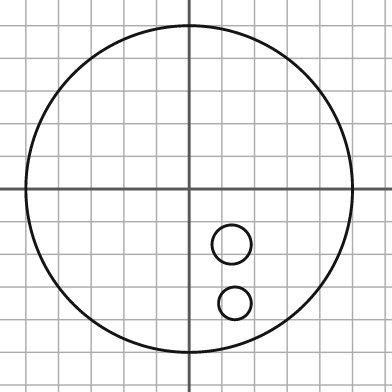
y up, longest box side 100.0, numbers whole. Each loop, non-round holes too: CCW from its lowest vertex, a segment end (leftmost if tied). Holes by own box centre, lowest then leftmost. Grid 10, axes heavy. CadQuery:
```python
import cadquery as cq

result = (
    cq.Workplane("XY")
    .moveTo(0.0, 0.0)
    .circle(50.0)
    .moveTo(14.0, -35.0)
    .circle(5.0)
    .moveTo(13.0, -17.0)
    .circle(6.0)
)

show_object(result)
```